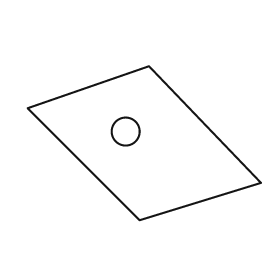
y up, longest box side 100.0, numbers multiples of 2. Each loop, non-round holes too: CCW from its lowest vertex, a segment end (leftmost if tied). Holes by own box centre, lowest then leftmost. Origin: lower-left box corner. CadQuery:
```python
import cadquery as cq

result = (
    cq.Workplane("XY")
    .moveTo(48.0, 0.0)
    .lineTo(100.0, 16.0)
    .lineTo(52.0, 66.0)
    .lineTo(0.0, 48.0)
    .close()
    .moveTo(42.0, 38.0)
    .circle(6.0)
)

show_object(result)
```